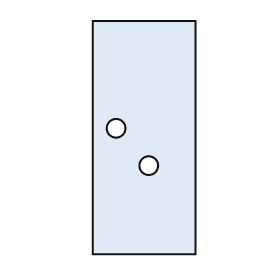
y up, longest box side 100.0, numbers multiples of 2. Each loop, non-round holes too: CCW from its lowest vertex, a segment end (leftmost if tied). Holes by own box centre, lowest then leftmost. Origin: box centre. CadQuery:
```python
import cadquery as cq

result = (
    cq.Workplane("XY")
    .moveTo(-22.0, -50.0)
    .lineTo(22.0, -50.0)
    .lineTo(22.0, 50.0)
    .lineTo(-22.0, 50.0)
    .close()
    .moveTo(2.0, -12.0)
    .circle(4.0)
    .moveTo(-12.0, 4.0)
    .circle(4.0)
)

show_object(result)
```